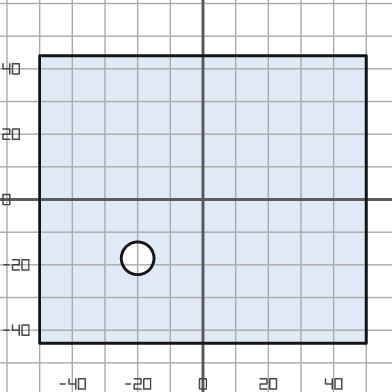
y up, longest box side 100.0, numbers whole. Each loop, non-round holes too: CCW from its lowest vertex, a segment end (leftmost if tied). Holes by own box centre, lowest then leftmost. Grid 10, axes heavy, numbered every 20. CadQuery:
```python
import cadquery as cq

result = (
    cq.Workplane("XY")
    .moveTo(-50.0, -44.0)
    .lineTo(50.0, -44.0)
    .lineTo(50.0, 44.0)
    .lineTo(-50.0, 44.0)
    .close()
    .moveTo(-20.0, -18.0)
    .circle(5.0)
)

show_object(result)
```